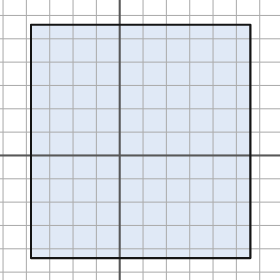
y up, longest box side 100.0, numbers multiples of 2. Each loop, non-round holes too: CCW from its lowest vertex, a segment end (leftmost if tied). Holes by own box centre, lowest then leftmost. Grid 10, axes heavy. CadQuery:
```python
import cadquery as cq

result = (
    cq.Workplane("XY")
    .moveTo(-38.0, -44.0)
    .lineTo(56.0, -44.0)
    .lineTo(56.0, 56.0)
    .lineTo(-38.0, 56.0)
    .close()
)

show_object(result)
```